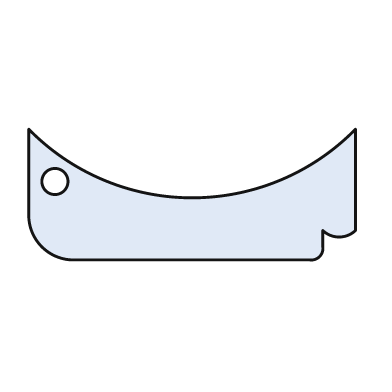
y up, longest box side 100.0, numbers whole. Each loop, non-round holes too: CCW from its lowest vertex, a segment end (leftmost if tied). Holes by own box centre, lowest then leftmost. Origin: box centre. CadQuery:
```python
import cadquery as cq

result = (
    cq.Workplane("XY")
    .moveTo(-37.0, -20.0)
    .lineTo(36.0, -20.0)
    .threePointArc((39.0, -19.0), (40.0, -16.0))
    .lineTo(40.0, -11.0)
    .threePointArc((45.0, -13.0), (50.0, -11.0))
    .lineTo(50.0, 20.0)
    .threePointArc((0.0, -1.0), (-50.0, 20.0))
    .lineTo(-50.0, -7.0)
    .threePointArc((-46.0, -16.0), (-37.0, -20.0))
    .close()
    .moveTo(-42.0, 4.0)
    .circle(4.0)
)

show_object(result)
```